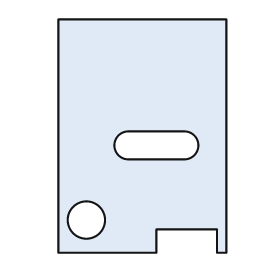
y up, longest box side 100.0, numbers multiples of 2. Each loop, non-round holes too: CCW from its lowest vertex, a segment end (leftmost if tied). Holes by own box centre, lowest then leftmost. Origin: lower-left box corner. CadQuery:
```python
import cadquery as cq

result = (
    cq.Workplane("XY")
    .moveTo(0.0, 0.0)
    .lineTo(42.0, 0.0)
    .lineTo(42.0, 10.0)
    .lineTo(68.0, 10.0)
    .lineTo(68.0, 0.0)
    .lineTo(72.0, 0.0)
    .lineTo(72.0, 100.0)
    .lineTo(0.0, 100.0)
    .close()
    .moveTo(12.0, 14.0)
    .circle(8.0)
    .moveTo(30.0, 40.0)
    .lineTo(54.0, 40.0)
    .threePointArc((60.0, 46.0), (54.0, 52.0))
    .lineTo(30.0, 52.0)
    .threePointArc((24.0, 46.0), (30.0, 40.0))
    .close()
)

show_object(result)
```